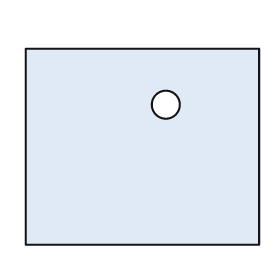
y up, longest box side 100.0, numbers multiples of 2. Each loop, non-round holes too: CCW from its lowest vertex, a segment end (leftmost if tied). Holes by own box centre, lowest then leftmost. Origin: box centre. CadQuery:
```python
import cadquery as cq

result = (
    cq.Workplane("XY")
    .moveTo(-50.0, -42.0)
    .lineTo(50.0, -42.0)
    .lineTo(50.0, 42.0)
    .lineTo(-50.0, 42.0)
    .close()
    .moveTo(10.0, 18.0)
    .circle(6.0)
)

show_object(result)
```